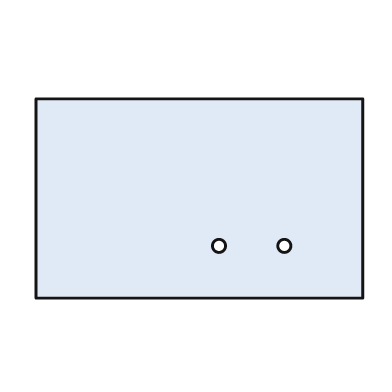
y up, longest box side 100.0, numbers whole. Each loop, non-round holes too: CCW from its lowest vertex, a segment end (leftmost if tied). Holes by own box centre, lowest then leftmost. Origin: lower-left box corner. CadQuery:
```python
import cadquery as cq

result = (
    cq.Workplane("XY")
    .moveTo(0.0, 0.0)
    .lineTo(100.0, 0.0)
    .lineTo(100.0, 61.0)
    .lineTo(0.0, 61.0)
    .close()
    .moveTo(56.0, 16.0)
    .circle(2.0)
    .moveTo(76.0, 16.0)
    .circle(2.0)
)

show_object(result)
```